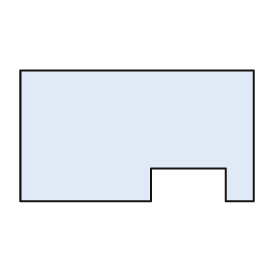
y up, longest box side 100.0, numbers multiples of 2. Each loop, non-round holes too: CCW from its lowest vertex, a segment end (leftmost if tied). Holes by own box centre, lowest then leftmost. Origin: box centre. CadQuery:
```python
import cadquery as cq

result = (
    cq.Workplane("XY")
    .moveTo(-50.0, -28.0)
    .lineTo(6.0, -28.0)
    .lineTo(6.0, -14.0)
    .lineTo(38.0, -14.0)
    .lineTo(38.0, -28.0)
    .lineTo(50.0, -28.0)
    .lineTo(50.0, 28.0)
    .lineTo(-50.0, 28.0)
    .close()
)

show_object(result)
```